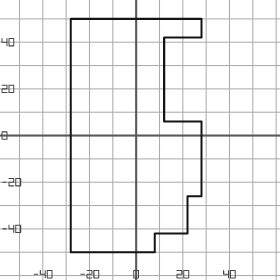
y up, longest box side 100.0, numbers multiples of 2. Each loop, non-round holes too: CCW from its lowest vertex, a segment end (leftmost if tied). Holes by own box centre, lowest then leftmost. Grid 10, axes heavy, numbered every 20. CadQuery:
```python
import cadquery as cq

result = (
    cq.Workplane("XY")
    .moveTo(-28.0, -50.0)
    .lineTo(8.0, -50.0)
    .lineTo(8.0, -42.0)
    .lineTo(22.0, -42.0)
    .lineTo(22.0, -26.0)
    .lineTo(28.0, -26.0)
    .lineTo(28.0, 6.0)
    .lineTo(12.0, 6.0)
    .lineTo(12.0, 42.0)
    .lineTo(28.0, 42.0)
    .lineTo(28.0, 50.0)
    .lineTo(-28.0, 50.0)
    .close()
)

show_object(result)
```